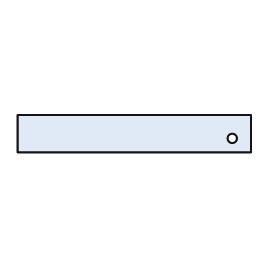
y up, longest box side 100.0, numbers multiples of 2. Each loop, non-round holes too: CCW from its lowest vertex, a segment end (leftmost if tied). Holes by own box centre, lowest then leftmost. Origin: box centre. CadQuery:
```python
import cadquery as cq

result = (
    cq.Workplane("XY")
    .moveTo(-50.0, -8.0)
    .lineTo(50.0, -8.0)
    .lineTo(50.0, 8.0)
    .lineTo(-50.0, 8.0)
    .close()
    .moveTo(42.0, -2.0)
    .circle(2.0)
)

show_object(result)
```